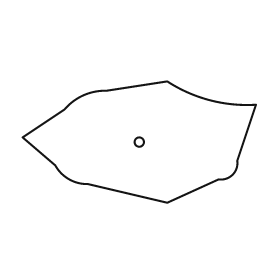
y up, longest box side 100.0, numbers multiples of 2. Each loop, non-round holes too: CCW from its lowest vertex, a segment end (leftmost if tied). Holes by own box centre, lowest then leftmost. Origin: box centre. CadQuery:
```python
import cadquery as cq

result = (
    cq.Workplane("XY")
    .moveTo(12.0, -26.0)
    .lineTo(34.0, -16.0)
    .threePointArc((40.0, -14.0), (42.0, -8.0))
    .lineTo(50.0, 16.0)
    .threePointArc((30.0, 18.0), (12.0, 26.0))
    .lineTo(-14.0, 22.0)
    .threePointArc((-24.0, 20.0), (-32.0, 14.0))
    .lineTo(-50.0, 2.0)
    .lineTo(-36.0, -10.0)
    .threePointArc((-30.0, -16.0), (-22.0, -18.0))
    .close()
    .moveTo(0.0, 0.0)
    .circle(2.0)
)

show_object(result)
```